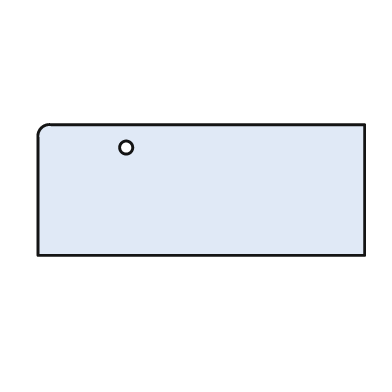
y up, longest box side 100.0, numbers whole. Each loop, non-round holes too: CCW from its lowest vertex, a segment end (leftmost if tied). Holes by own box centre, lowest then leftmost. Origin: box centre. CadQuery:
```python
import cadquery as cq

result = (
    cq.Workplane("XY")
    .moveTo(-50.0, -20.0)
    .lineTo(50.0, -20.0)
    .lineTo(50.0, 20.0)
    .lineTo(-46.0, 20.0)
    .threePointArc((-49.0, 19.0), (-50.0, 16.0))
    .close()
    .moveTo(-23.0, 13.0)
    .circle(2.0)
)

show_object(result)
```